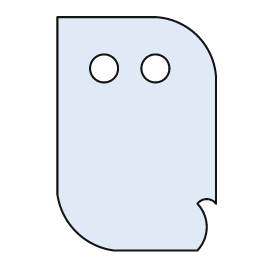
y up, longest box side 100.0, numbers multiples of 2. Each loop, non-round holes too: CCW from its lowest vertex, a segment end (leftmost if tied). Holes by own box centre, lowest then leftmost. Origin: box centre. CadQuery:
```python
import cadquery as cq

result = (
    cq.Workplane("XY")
    .moveTo(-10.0, -50.0)
    .lineTo(26.0, -50.0)
    .threePointArc((30.0, -40.0), (26.0, -30.0))
    .threePointArc((30.0, -28.0), (34.0, -30.0))
    .lineTo(34.0, 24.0)
    .threePointArc((26.0, 42.0), (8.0, 50.0))
    .lineTo(-34.0, 50.0)
    .lineTo(-34.0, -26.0)
    .threePointArc((-26.0, -42.0), (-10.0, -50.0))
    .close()
    .moveTo(-14.0, 28.0)
    .circle(6.0)
    .moveTo(8.0, 28.0)
    .circle(6.0)
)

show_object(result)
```